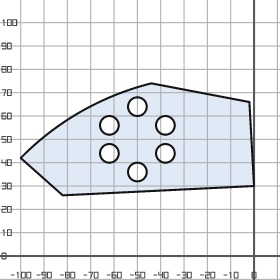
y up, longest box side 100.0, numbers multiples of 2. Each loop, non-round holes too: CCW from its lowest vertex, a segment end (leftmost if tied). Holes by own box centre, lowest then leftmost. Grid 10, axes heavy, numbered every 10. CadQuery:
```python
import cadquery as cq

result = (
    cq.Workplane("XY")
    .moveTo(-82.0, 26.0)
    .lineTo(0.0, 30.0)
    .lineTo(-2.0, 66.0)
    .lineTo(-44.0, 74.0)
    .threePointArc((-74.0, 62.0), (-100.0, 42.0))
    .close()
    .moveTo(-50.0, 36.0)
    .circle(4.0)
    .moveTo(-62.0, 44.0)
    .circle(4.0)
    .moveTo(-38.0, 44.0)
    .circle(4.0)
    .moveTo(-62.0, 56.0)
    .circle(4.0)
    .moveTo(-38.0, 56.0)
    .circle(4.0)
    .moveTo(-50.0, 64.0)
    .circle(4.0)
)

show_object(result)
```